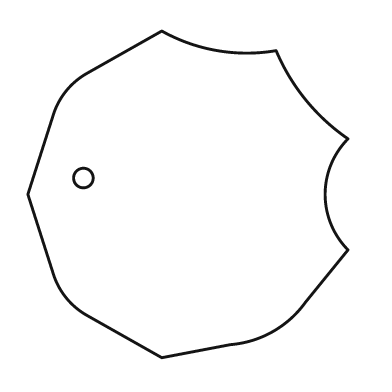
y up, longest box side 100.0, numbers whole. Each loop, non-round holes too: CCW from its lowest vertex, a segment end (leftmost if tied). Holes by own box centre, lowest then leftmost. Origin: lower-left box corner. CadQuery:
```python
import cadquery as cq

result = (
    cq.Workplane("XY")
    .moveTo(41.0, 0.0)
    .lineTo(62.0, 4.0)
    .threePointArc((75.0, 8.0), (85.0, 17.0))
    .lineTo(98.0, 33.0)
    .threePointArc((91.0, 50.0), (98.0, 67.0))
    .threePointArc((85.0, 79.0), (76.0, 94.0))
    .threePointArc((58.0, 94.0), (41.0, 100.0))
    .lineTo(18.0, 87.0)
    .threePointArc((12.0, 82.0), (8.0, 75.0))
    .lineTo(0.0, 50.0)
    .lineTo(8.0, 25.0)
    .threePointArc((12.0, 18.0), (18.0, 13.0))
    .close()
    .moveTo(17.0, 55.0)
    .circle(3.0)
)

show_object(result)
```